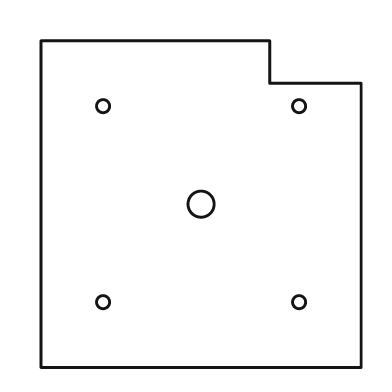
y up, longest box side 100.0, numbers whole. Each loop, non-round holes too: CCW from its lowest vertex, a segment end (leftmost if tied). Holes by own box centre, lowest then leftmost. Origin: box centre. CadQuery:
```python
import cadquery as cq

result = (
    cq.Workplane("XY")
    .moveTo(-49.0, -50.0)
    .lineTo(49.0, -50.0)
    .lineTo(49.0, 37.0)
    .lineTo(21.0, 37.0)
    .lineTo(21.0, 50.0)
    .lineTo(-49.0, 50.0)
    .close()
    .moveTo(-30.0, -30.0)
    .circle(2.0)
    .moveTo(30.0, -30.0)
    .circle(2.0)
    .moveTo(0.0, 0.0)
    .circle(4.0)
    .moveTo(-30.0, 30.0)
    .circle(2.0)
    .moveTo(30.0, 30.0)
    .circle(2.0)
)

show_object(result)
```